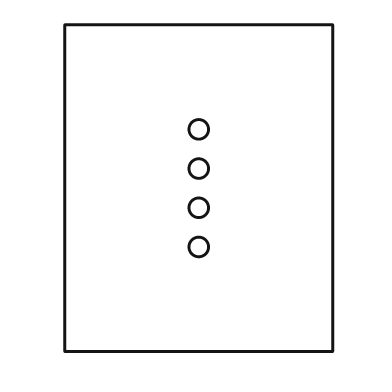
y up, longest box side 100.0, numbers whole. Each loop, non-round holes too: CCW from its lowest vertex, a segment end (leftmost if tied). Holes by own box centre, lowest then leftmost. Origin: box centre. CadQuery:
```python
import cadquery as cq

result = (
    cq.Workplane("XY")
    .moveTo(-41.0, -50.0)
    .lineTo(41.0, -50.0)
    .lineTo(41.0, 50.0)
    .lineTo(-41.0, 50.0)
    .close()
    .moveTo(0.0, -18.0)
    .circle(3.0)
    .moveTo(0.0, -6.0)
    .circle(3.0)
    .moveTo(0.0, 6.0)
    .circle(3.0)
    .moveTo(0.0, 18.0)
    .circle(3.0)
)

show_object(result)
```